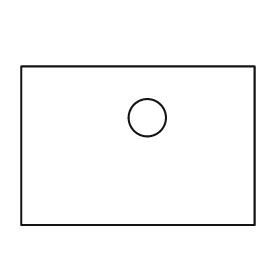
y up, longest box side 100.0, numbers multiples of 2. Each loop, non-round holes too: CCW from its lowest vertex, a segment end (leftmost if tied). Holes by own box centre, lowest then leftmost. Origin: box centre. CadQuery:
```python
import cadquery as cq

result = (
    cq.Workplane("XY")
    .moveTo(-50.0, -34.0)
    .lineTo(50.0, -34.0)
    .lineTo(50.0, 34.0)
    .lineTo(-50.0, 34.0)
    .close()
    .moveTo(4.0, 12.0)
    .circle(8.0)
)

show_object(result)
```